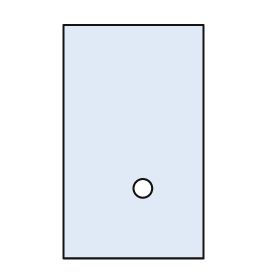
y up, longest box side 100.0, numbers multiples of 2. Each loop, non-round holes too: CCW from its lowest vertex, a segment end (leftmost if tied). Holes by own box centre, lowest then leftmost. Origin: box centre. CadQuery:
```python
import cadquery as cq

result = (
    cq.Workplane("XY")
    .moveTo(-30.0, -50.0)
    .lineTo(30.0, -50.0)
    .lineTo(30.0, 50.0)
    .lineTo(-30.0, 50.0)
    .close()
    .moveTo(4.0, -20.0)
    .circle(4.0)
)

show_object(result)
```